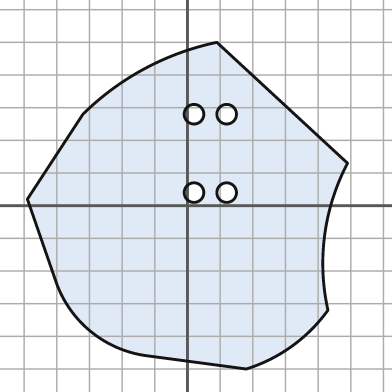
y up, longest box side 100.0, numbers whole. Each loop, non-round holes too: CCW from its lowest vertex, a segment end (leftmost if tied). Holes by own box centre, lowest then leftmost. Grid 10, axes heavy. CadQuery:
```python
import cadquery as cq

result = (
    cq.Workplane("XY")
    .moveTo(18.0, -50.0)
    .threePointArc((32.0, -43.0), (43.0, -32.0))
    .threePointArc((42.0, -9.0), (49.0, 13.0))
    .lineTo(9.0, 50.0)
    .threePointArc((-13.0, 42.0), (-32.0, 28.0))
    .lineTo(-49.0, 2.0)
    .lineTo(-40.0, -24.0)
    .threePointArc((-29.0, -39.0), (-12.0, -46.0))
    .close()
    .moveTo(2.0, 4.0)
    .circle(3.0)
    .moveTo(12.0, 4.0)
    .circle(3.0)
    .moveTo(2.0, 28.0)
    .circle(3.0)
    .moveTo(12.0, 28.0)
    .circle(3.0)
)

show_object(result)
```